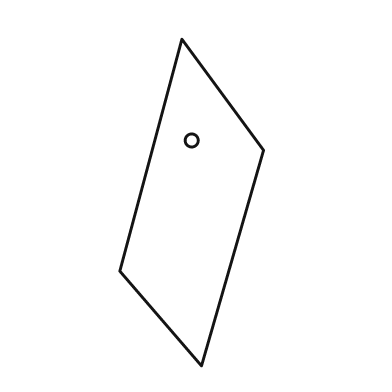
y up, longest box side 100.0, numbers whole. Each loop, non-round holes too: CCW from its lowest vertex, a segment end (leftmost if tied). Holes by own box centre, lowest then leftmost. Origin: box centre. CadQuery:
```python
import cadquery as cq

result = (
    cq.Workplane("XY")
    .moveTo(3.0, -50.0)
    .lineTo(22.0, 16.0)
    .lineTo(-3.0, 50.0)
    .lineTo(-22.0, -21.0)
    .close()
    .moveTo(0.0, 19.0)
    .circle(2.0)
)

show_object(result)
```